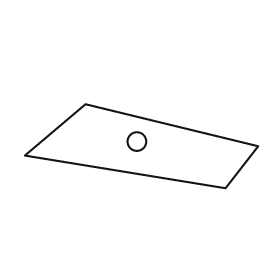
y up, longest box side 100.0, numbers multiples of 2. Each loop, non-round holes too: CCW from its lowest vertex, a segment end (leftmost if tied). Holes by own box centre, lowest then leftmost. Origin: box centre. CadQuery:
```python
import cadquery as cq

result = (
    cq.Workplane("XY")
    .moveTo(36.0, -18.0)
    .lineTo(50.0, 0.0)
    .lineTo(-24.0, 18.0)
    .lineTo(-50.0, -4.0)
    .close()
    .moveTo(-2.0, 2.0)
    .circle(4.0)
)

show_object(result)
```